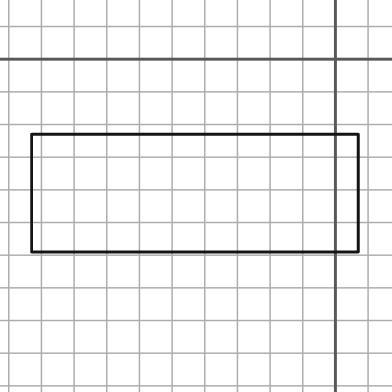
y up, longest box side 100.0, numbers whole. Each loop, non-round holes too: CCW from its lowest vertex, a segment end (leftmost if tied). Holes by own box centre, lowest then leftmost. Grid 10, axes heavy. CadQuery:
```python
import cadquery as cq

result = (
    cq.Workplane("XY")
    .moveTo(-93.0, -59.0)
    .lineTo(7.0, -59.0)
    .lineTo(7.0, -23.0)
    .lineTo(-93.0, -23.0)
    .close()
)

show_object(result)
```